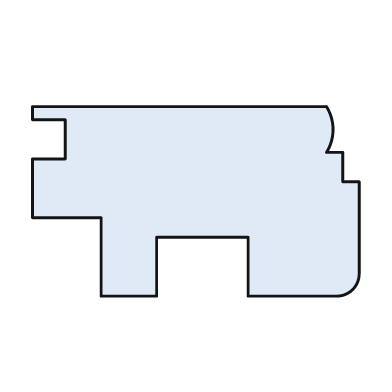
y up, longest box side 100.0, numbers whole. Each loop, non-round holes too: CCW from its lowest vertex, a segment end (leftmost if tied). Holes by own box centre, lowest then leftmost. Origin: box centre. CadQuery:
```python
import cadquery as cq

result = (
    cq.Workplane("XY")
    .moveTo(-29.0, -29.0)
    .lineTo(-12.0, -29.0)
    .lineTo(-12.0, -11.0)
    .lineTo(16.0, -11.0)
    .lineTo(16.0, -29.0)
    .lineTo(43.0, -29.0)
    .threePointArc((48.0, -27.0), (50.0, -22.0))
    .lineTo(50.0, 6.0)
    .lineTo(45.0, 6.0)
    .lineTo(45.0, 15.0)
    .lineTo(40.0, 15.0)
    .threePointArc((42.0, 22.0), (40.0, 29.0))
    .lineTo(-50.0, 29.0)
    .lineTo(-50.0, 25.0)
    .lineTo(-40.0, 25.0)
    .lineTo(-40.0, 13.0)
    .lineTo(-50.0, 13.0)
    .lineTo(-50.0, -5.0)
    .lineTo(-29.0, -5.0)
    .close()
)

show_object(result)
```